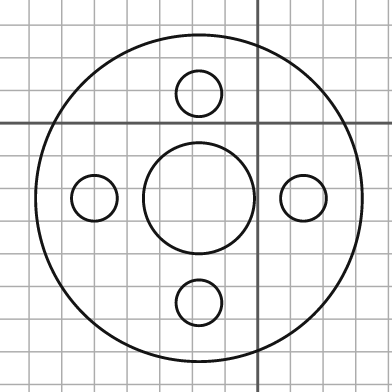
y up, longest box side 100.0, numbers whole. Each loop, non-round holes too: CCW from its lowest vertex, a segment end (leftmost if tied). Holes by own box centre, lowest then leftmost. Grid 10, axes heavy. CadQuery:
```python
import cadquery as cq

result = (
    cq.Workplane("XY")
    .moveTo(-18.0, -23.0)
    .circle(50.0)
    .moveTo(-18.0, -55.0)
    .circle(7.0)
    .moveTo(-50.0, -23.0)
    .circle(7.0)
    .moveTo(-18.0, -23.0)
    .circle(17.0)
    .moveTo(14.0, -23.0)
    .circle(7.0)
    .moveTo(-18.0, 9.0)
    .circle(7.0)
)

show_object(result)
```